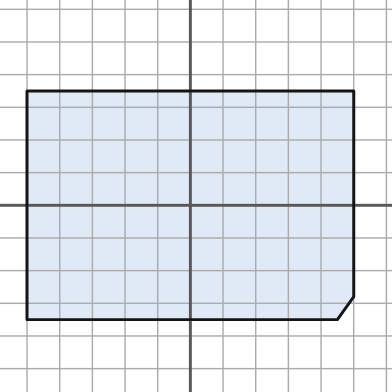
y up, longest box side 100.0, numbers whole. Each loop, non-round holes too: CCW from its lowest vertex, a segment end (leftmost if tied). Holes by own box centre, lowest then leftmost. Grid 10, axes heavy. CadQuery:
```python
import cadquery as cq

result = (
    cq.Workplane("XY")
    .moveTo(-50.0, -35.0)
    .lineTo(45.0, -35.0)
    .lineTo(50.0, -28.0)
    .lineTo(50.0, 35.0)
    .lineTo(-50.0, 35.0)
    .close()
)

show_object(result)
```